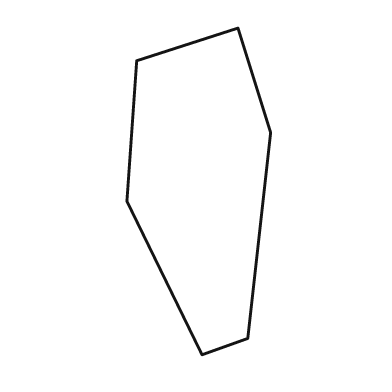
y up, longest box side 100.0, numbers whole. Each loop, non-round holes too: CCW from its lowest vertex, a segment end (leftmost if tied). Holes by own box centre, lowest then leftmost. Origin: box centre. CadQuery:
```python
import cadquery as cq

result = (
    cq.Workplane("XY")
    .moveTo(1.0, -50.0)
    .lineTo(15.0, -45.0)
    .lineTo(22.0, 18.0)
    .lineTo(12.0, 50.0)
    .lineTo(-19.0, 40.0)
    .lineTo(-22.0, -3.0)
    .close()
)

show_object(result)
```